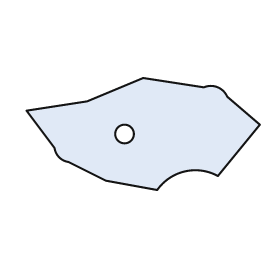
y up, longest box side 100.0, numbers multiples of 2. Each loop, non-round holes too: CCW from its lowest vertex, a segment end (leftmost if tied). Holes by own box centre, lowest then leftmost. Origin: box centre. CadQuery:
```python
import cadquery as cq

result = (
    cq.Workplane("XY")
    .moveTo(6.0, -24.0)
    .threePointArc((18.0, -16.0), (32.0, -18.0))
    .lineTo(50.0, 4.0)
    .lineTo(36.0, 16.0)
    .threePointArc((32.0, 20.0), (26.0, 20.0))
    .lineTo(0.0, 24.0)
    .lineTo(-24.0, 14.0)
    .lineTo(-50.0, 10.0)
    .lineTo(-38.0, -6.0)
    .threePointArc((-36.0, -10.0), (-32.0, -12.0))
    .lineTo(-16.0, -20.0)
    .close()
    .moveTo(-8.0, 0.0)
    .circle(4.0)
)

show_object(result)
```